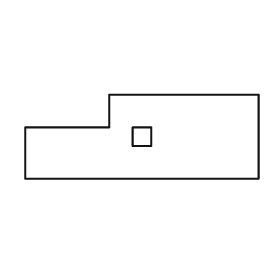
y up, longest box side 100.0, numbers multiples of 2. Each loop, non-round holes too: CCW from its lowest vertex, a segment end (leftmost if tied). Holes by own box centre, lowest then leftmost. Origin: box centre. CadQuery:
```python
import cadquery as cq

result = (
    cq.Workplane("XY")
    .moveTo(-50.0, -18.0)
    .lineTo(50.0, -18.0)
    .lineTo(50.0, 18.0)
    .lineTo(-14.0, 18.0)
    .lineTo(-14.0, 4.0)
    .lineTo(-50.0, 4.0)
    .close()
    .moveTo(-4.0, -4.0)
    .lineTo(4.0, -4.0)
    .lineTo(4.0, 4.0)
    .lineTo(-4.0, 4.0)
    .close()
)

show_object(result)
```